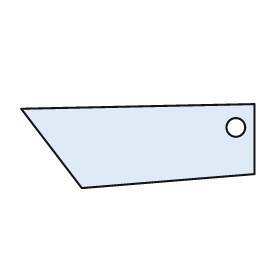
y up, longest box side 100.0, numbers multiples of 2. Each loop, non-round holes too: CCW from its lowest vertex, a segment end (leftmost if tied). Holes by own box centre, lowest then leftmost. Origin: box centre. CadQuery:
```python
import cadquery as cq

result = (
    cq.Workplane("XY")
    .moveTo(-24.0, -18.0)
    .lineTo(50.0, -12.0)
    .lineTo(50.0, 18.0)
    .lineTo(-50.0, 16.0)
    .close()
    .moveTo(42.0, 8.0)
    .circle(4.0)
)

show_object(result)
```